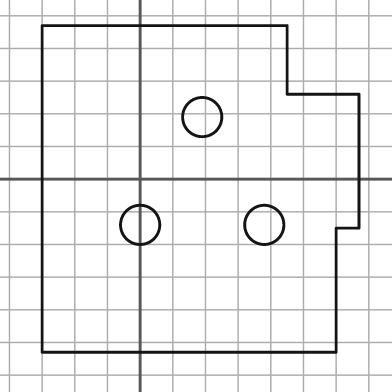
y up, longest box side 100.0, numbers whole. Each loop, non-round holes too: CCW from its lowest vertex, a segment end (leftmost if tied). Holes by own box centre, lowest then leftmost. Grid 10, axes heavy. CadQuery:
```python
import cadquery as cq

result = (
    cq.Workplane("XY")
    .moveTo(-30.0, -53.0)
    .lineTo(60.0, -53.0)
    .lineTo(60.0, -15.0)
    .lineTo(67.0, -15.0)
    .lineTo(67.0, 26.0)
    .lineTo(45.0, 26.0)
    .lineTo(45.0, 47.0)
    .lineTo(-30.0, 47.0)
    .close()
    .moveTo(0.0, -14.0)
    .circle(6.0)
    .moveTo(38.0, -14.0)
    .circle(6.0)
    .moveTo(19.0, 19.0)
    .circle(6.0)
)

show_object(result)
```